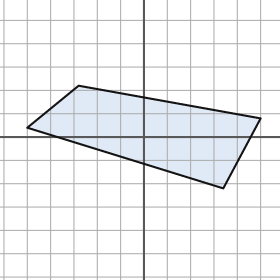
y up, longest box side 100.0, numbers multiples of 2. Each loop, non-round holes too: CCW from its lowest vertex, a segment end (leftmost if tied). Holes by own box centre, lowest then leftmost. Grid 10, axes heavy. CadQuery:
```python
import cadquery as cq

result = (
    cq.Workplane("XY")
    .moveTo(34.0, -22.0)
    .lineTo(50.0, 8.0)
    .lineTo(-28.0, 22.0)
    .lineTo(-50.0, 4.0)
    .close()
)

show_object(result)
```